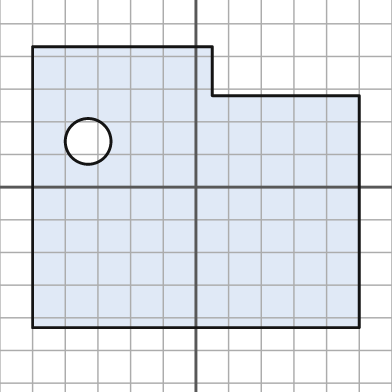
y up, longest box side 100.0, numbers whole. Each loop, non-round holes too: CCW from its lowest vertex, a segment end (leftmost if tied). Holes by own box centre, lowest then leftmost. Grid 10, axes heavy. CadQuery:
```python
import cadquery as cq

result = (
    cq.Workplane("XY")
    .moveTo(-50.0, -43.0)
    .lineTo(50.0, -43.0)
    .lineTo(50.0, 28.0)
    .lineTo(5.0, 28.0)
    .lineTo(5.0, 43.0)
    .lineTo(-50.0, 43.0)
    .close()
    .moveTo(-33.0, 14.0)
    .circle(7.0)
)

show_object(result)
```